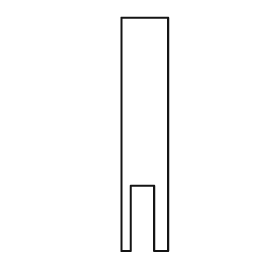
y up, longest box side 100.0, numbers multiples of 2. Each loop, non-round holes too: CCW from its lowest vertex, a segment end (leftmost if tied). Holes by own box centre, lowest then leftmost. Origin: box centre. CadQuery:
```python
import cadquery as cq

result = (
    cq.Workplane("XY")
    .moveTo(-10.0, -50.0)
    .lineTo(-6.0, -50.0)
    .lineTo(-6.0, -22.0)
    .lineTo(4.0, -22.0)
    .lineTo(4.0, -50.0)
    .lineTo(10.0, -50.0)
    .lineTo(10.0, 50.0)
    .lineTo(-10.0, 50.0)
    .close()
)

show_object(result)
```